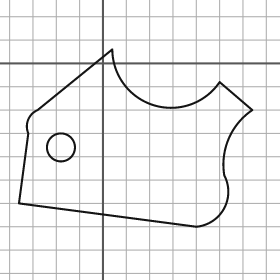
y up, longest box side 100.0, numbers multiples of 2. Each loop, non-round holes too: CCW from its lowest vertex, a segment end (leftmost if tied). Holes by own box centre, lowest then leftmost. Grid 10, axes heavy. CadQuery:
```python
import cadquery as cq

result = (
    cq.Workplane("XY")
    .moveTo(40.0, -70.0)
    .threePointArc((52.0, -62.0), (52.0, -48.0))
    .threePointArc((54.0, -32.0), (64.0, -20.0))
    .lineTo(50.0, -8.0)
    .threePointArc((22.0, -18.0), (4.0, 6.0))
    .lineTo(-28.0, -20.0)
    .threePointArc((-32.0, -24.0), (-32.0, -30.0))
    .lineTo(-36.0, -60.0)
    .close()
    .moveTo(-18.0, -36.0)
    .circle(6.0)
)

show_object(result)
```